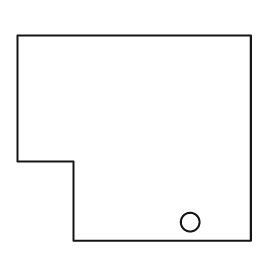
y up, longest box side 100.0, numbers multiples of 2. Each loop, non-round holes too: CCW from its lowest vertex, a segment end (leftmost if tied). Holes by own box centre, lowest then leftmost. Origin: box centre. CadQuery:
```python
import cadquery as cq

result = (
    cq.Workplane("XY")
    .moveTo(-26.0, -44.0)
    .lineTo(50.0, -44.0)
    .lineTo(50.0, 44.0)
    .lineTo(-50.0, 44.0)
    .lineTo(-50.0, -10.0)
    .lineTo(-26.0, -10.0)
    .close()
    .moveTo(24.0, -36.0)
    .circle(4.0)
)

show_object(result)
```